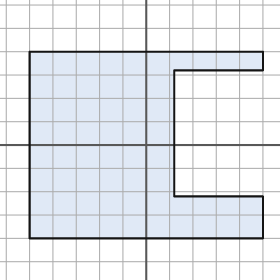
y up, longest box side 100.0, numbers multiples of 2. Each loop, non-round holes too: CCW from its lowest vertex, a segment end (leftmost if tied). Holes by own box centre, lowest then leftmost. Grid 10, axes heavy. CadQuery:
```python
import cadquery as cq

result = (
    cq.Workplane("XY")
    .moveTo(-50.0, -40.0)
    .lineTo(50.0, -40.0)
    .lineTo(50.0, -22.0)
    .lineTo(12.0, -22.0)
    .lineTo(12.0, 32.0)
    .lineTo(50.0, 32.0)
    .lineTo(50.0, 40.0)
    .lineTo(-50.0, 40.0)
    .close()
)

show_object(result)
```